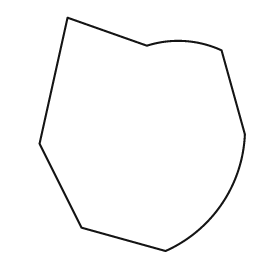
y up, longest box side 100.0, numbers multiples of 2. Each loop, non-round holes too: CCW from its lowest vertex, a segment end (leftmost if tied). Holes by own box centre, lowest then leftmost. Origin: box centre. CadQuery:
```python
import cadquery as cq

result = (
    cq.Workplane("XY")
    .moveTo(10.0, -50.0)
    .threePointArc((34.0, -30.0), (44.0, 0.0))
    .lineTo(34.0, 36.0)
    .threePointArc((18.0, 40.0), (2.0, 38.0))
    .lineTo(-32.0, 50.0)
    .lineTo(-44.0, -4.0)
    .lineTo(-26.0, -40.0)
    .close()
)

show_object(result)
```